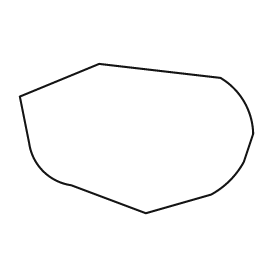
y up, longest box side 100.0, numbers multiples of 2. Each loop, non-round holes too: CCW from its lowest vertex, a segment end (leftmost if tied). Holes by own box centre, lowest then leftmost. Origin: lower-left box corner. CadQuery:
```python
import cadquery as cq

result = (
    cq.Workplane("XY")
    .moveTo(54.0, 0.0)
    .lineTo(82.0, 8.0)
    .threePointArc((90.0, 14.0), (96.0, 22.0))
    .lineTo(100.0, 34.0)
    .threePointArc((96.0, 48.0), (86.0, 58.0))
    .lineTo(34.0, 64.0)
    .lineTo(0.0, 50.0)
    .lineTo(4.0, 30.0)
    .threePointArc((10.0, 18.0), (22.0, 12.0))
    .close()
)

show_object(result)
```